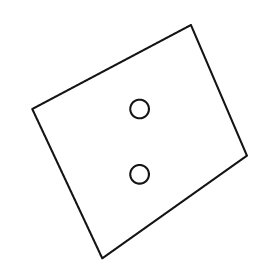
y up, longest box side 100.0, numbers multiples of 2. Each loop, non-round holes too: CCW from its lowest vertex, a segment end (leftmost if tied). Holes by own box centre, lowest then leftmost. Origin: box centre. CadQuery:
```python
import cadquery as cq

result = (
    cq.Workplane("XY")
    .moveTo(-16.0, -50.0)
    .lineTo(46.0, -6.0)
    .lineTo(22.0, 50.0)
    .lineTo(-46.0, 14.0)
    .close()
    .moveTo(0.0, -14.0)
    .circle(4.0)
    .moveTo(0.0, 14.0)
    .circle(4.0)
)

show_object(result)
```